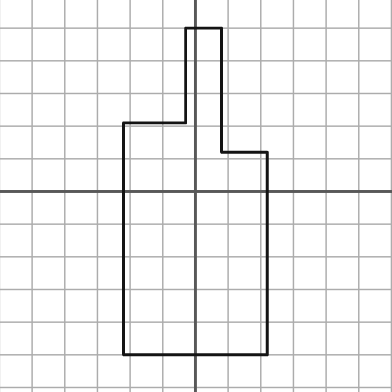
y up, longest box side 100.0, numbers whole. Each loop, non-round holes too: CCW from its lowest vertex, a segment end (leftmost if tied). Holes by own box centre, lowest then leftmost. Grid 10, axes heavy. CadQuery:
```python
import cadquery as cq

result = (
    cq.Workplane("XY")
    .moveTo(-22.0, -50.0)
    .lineTo(22.0, -50.0)
    .lineTo(22.0, 12.0)
    .lineTo(8.0, 12.0)
    .lineTo(8.0, 50.0)
    .lineTo(-3.0, 50.0)
    .lineTo(-3.0, 21.0)
    .lineTo(-22.0, 21.0)
    .close()
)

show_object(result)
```